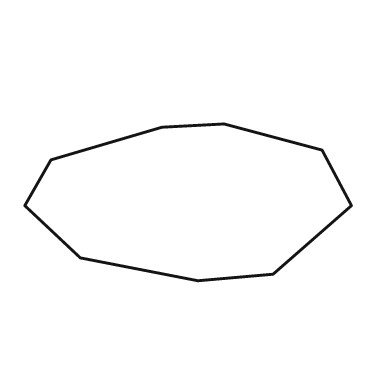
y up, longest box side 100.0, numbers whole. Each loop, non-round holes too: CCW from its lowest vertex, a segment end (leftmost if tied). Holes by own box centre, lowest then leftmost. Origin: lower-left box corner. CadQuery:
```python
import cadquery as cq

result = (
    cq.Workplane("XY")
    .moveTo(53.0, 0.0)
    .lineTo(76.0, 2.0)
    .lineTo(100.0, 23.0)
    .lineTo(91.0, 40.0)
    .lineTo(61.0, 48.0)
    .lineTo(42.0, 47.0)
    .lineTo(8.0, 37.0)
    .lineTo(0.0, 23.0)
    .lineTo(17.0, 7.0)
    .close()
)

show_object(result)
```